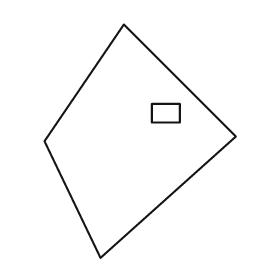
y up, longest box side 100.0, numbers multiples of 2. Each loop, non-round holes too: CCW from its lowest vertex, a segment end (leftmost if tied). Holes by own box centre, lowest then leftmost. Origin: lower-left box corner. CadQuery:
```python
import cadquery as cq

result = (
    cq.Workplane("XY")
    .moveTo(24.0, 0.0)
    .lineTo(82.0, 52.0)
    .lineTo(34.0, 100.0)
    .lineTo(0.0, 50.0)
    .close()
    .moveTo(46.0, 58.0)
    .lineTo(58.0, 58.0)
    .lineTo(58.0, 66.0)
    .lineTo(46.0, 66.0)
    .close()
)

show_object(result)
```